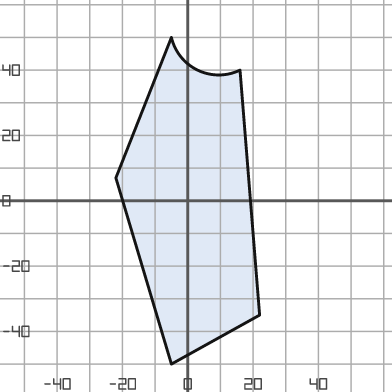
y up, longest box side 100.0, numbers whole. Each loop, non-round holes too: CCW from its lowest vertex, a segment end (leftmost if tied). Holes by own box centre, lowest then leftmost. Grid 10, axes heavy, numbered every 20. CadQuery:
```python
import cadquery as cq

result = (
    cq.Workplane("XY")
    .moveTo(-5.0, -50.0)
    .lineTo(22.0, -35.0)
    .lineTo(16.0, 40.0)
    .threePointArc((3.0, 40.0), (-5.0, 50.0))
    .lineTo(-22.0, 7.0)
    .close()
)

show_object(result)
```